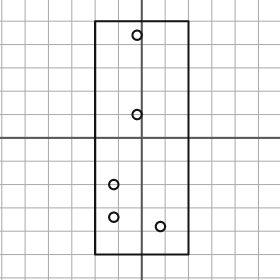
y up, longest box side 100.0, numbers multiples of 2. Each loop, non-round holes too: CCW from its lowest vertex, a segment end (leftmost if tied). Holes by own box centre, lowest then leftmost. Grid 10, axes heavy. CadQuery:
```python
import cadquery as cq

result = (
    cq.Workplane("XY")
    .moveTo(-20.0, -50.0)
    .lineTo(20.0, -50.0)
    .lineTo(20.0, 50.0)
    .lineTo(-20.0, 50.0)
    .close()
    .moveTo(8.0, -38.0)
    .circle(2.0)
    .moveTo(-12.0, -34.0)
    .circle(2.0)
    .moveTo(-12.0, -20.0)
    .circle(2.0)
    .moveTo(-2.0, 10.0)
    .circle(2.0)
    .moveTo(-2.0, 44.0)
    .circle(2.0)
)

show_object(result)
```